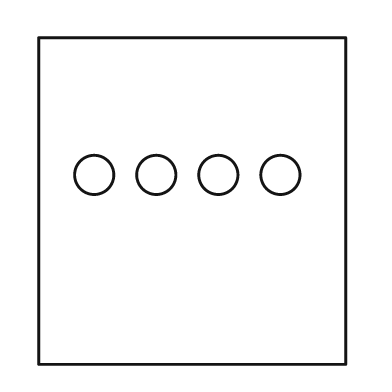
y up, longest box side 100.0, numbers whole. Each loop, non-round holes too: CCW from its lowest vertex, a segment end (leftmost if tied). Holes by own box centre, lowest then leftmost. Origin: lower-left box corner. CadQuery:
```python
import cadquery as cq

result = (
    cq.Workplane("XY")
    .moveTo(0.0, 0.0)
    .lineTo(94.0, 0.0)
    .lineTo(94.0, 100.0)
    .lineTo(0.0, 100.0)
    .close()
    .moveTo(17.0, 58.0)
    .circle(6.0)
    .moveTo(36.0, 58.0)
    .circle(6.0)
    .moveTo(55.0, 58.0)
    .circle(6.0)
    .moveTo(74.0, 58.0)
    .circle(6.0)
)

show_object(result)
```